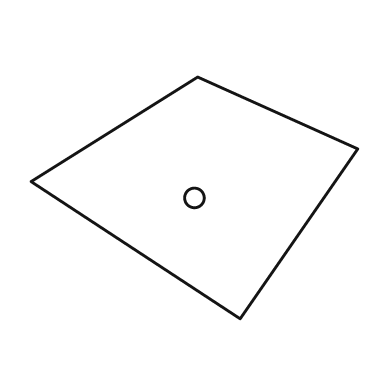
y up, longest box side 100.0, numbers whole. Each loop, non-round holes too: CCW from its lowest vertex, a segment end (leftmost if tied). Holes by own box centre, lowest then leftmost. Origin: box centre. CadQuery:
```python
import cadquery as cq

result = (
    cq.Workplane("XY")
    .moveTo(14.0, -37.0)
    .lineTo(50.0, 15.0)
    .lineTo(1.0, 37.0)
    .lineTo(-50.0, 5.0)
    .close()
    .moveTo(0.0, 0.0)
    .circle(3.0)
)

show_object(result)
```